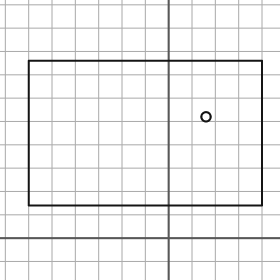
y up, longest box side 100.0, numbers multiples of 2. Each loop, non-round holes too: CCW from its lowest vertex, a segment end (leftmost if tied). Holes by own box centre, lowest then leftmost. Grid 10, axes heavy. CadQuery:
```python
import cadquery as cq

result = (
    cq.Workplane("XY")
    .moveTo(-60.0, 14.0)
    .lineTo(40.0, 14.0)
    .lineTo(40.0, 76.0)
    .lineTo(-60.0, 76.0)
    .close()
    .moveTo(16.0, 52.0)
    .circle(2.0)
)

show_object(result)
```